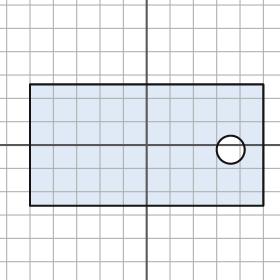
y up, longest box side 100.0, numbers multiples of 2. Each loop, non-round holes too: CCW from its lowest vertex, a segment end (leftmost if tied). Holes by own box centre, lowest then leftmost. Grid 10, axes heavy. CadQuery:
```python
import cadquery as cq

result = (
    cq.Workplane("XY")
    .moveTo(-50.0, -26.0)
    .lineTo(50.0, -26.0)
    .lineTo(50.0, 26.0)
    .lineTo(-50.0, 26.0)
    .close()
    .moveTo(36.0, -2.0)
    .circle(6.0)
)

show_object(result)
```